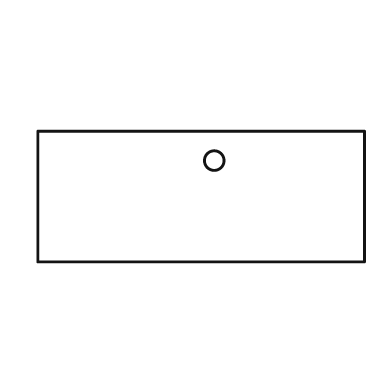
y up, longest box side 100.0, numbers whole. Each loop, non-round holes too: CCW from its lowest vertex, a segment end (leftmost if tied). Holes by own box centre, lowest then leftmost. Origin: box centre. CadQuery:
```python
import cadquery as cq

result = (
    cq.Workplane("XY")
    .moveTo(-50.0, -20.0)
    .lineTo(50.0, -20.0)
    .lineTo(50.0, 20.0)
    .lineTo(-50.0, 20.0)
    .close()
    .moveTo(4.0, 11.0)
    .circle(3.0)
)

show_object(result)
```